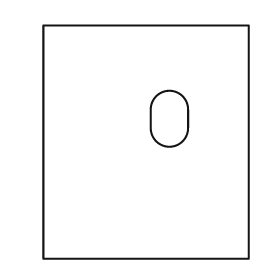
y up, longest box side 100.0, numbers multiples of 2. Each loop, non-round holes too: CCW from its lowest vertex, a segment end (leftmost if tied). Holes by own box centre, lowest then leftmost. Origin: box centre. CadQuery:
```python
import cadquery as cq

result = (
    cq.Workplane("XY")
    .moveTo(-44.0, -50.0)
    .lineTo(44.0, -50.0)
    .lineTo(44.0, 50.0)
    .lineTo(-44.0, 50.0)
    .close()
    .moveTo(2.0, 6.0)
    .threePointArc((10.0, -2.0), (18.0, 6.0))
    .lineTo(18.0, 14.0)
    .threePointArc((10.0, 22.0), (2.0, 14.0))
    .close()
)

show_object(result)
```